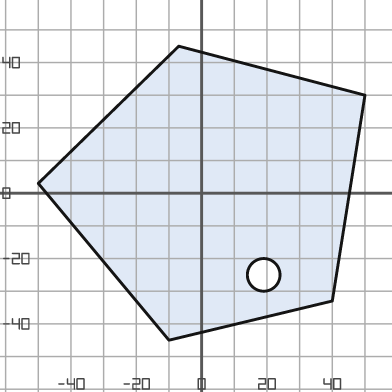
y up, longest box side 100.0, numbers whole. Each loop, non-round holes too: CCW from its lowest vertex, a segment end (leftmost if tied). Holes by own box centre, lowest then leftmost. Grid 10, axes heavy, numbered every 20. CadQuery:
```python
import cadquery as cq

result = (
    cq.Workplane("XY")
    .moveTo(-10.0, -45.0)
    .lineTo(40.0, -33.0)
    .lineTo(50.0, 30.0)
    .lineTo(-7.0, 45.0)
    .lineTo(-50.0, 3.0)
    .close()
    .moveTo(19.0, -25.0)
    .circle(5.0)
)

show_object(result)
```